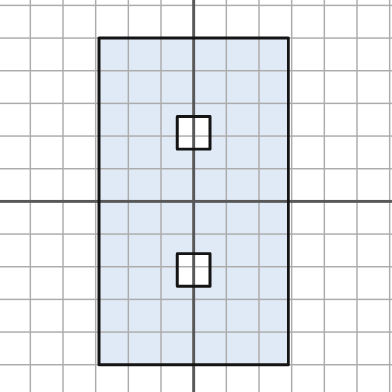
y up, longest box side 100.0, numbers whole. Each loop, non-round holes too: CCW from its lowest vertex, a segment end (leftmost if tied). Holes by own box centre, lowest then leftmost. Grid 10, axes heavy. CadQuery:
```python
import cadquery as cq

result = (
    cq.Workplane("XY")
    .moveTo(-29.0, -50.0)
    .lineTo(29.0, -50.0)
    .lineTo(29.0, 50.0)
    .lineTo(-29.0, 50.0)
    .close()
    .moveTo(-5.0, -26.0)
    .lineTo(5.0, -26.0)
    .lineTo(5.0, -16.0)
    .lineTo(-5.0, -16.0)
    .close()
    .moveTo(-5.0, 16.0)
    .lineTo(5.0, 16.0)
    .lineTo(5.0, 26.0)
    .lineTo(-5.0, 26.0)
    .close()
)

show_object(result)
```